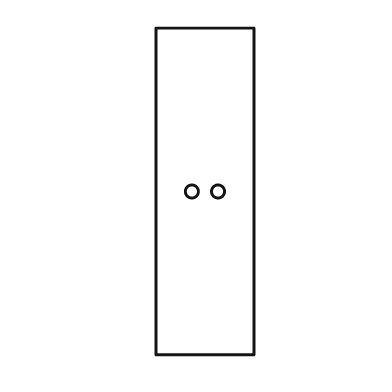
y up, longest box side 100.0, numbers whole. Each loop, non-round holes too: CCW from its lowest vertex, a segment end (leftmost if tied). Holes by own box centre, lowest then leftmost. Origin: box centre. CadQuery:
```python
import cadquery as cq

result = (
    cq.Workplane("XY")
    .moveTo(-15.0, -50.0)
    .lineTo(15.0, -50.0)
    .lineTo(15.0, 50.0)
    .lineTo(-15.0, 50.0)
    .close()
    .moveTo(-4.0, 0.0)
    .circle(2.0)
    .moveTo(4.0, 0.0)
    .circle(2.0)
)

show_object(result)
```